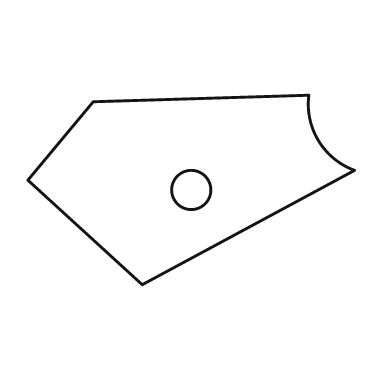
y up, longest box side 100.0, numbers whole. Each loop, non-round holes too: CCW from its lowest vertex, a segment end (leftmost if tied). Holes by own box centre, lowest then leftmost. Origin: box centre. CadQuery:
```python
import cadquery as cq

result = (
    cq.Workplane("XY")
    .moveTo(-15.0, -29.0)
    .lineTo(50.0, 6.0)
    .threePointArc((39.0, 15.0), (36.0, 29.0))
    .lineTo(-30.0, 27.0)
    .lineTo(-50.0, 3.0)
    .close()
    .moveTo(0.0, 0.0)
    .circle(6.0)
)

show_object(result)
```